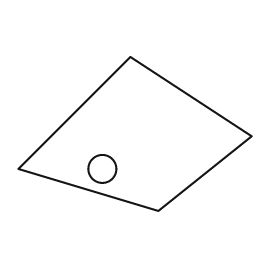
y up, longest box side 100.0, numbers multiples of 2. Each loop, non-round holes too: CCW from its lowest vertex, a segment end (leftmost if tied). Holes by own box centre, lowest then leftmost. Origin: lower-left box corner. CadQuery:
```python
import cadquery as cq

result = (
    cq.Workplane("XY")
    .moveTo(60.0, 0.0)
    .lineTo(100.0, 32.0)
    .lineTo(48.0, 66.0)
    .lineTo(0.0, 18.0)
    .close()
    .moveTo(36.0, 18.0)
    .circle(6.0)
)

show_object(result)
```